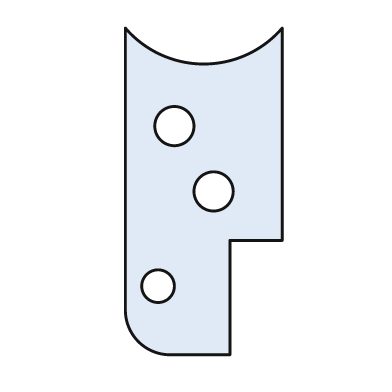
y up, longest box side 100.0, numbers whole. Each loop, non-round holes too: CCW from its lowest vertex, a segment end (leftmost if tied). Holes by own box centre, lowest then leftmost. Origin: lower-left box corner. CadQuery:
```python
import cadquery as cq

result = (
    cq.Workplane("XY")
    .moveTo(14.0, 0.0)
    .lineTo(32.0, 0.0)
    .lineTo(32.0, 35.0)
    .lineTo(48.0, 35.0)
    .lineTo(48.0, 100.0)
    .threePointArc((24.0, 89.0), (0.0, 100.0))
    .lineTo(0.0, 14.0)
    .threePointArc((4.0, 4.0), (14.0, 0.0))
    .close()
    .moveTo(10.0, 21.0)
    .circle(5.0)
    .moveTo(27.0, 50.0)
    .circle(6.0)
    .moveTo(15.0, 70.0)
    .circle(6.0)
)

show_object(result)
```